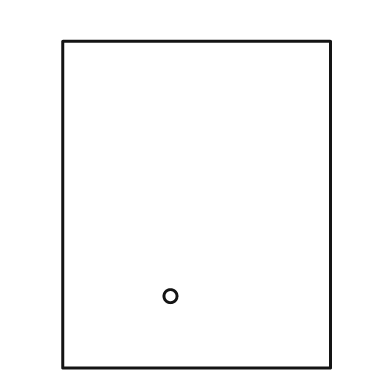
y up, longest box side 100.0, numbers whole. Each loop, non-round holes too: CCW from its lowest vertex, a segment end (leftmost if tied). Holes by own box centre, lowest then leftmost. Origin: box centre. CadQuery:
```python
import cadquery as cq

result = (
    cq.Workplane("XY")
    .moveTo(-41.0, -50.0)
    .lineTo(41.0, -50.0)
    .lineTo(41.0, 50.0)
    .lineTo(-41.0, 50.0)
    .close()
    .moveTo(-8.0, -28.0)
    .circle(2.0)
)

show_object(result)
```